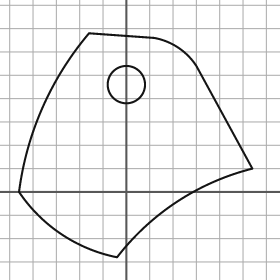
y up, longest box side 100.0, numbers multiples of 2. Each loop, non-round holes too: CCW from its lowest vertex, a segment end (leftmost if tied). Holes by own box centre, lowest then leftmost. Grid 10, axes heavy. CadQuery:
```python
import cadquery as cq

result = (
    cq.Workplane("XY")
    .moveTo(-4.0, -28.0)
    .threePointArc((22.0, -4.0), (54.0, 10.0))
    .lineTo(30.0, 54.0)
    .threePointArc((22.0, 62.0), (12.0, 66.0))
    .lineTo(-16.0, 68.0)
    .threePointArc((-36.0, 36.0), (-46.0, 0.0))
    .threePointArc((-28.0, -18.0), (-4.0, -28.0))
    .close()
    .moveTo(0.0, 46.0)
    .circle(8.0)
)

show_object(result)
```